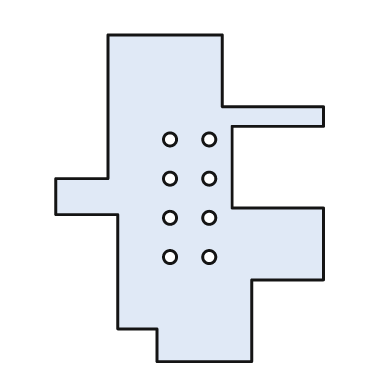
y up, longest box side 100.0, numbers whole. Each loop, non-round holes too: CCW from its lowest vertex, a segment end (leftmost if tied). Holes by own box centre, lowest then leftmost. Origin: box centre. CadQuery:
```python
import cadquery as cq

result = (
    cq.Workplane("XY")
    .moveTo(-10.0, -50.0)
    .lineTo(19.0, -50.0)
    .lineTo(19.0, -25.0)
    .lineTo(41.0, -25.0)
    .lineTo(41.0, -3.0)
    .lineTo(13.0, -3.0)
    .lineTo(13.0, 22.0)
    .lineTo(41.0, 22.0)
    .lineTo(41.0, 28.0)
    .lineTo(10.0, 28.0)
    .lineTo(10.0, 50.0)
    .lineTo(-25.0, 50.0)
    .lineTo(-25.0, 6.0)
    .lineTo(-41.0, 6.0)
    .lineTo(-41.0, -5.0)
    .lineTo(-22.0, -5.0)
    .lineTo(-22.0, -40.0)
    .lineTo(-10.0, -40.0)
    .close()
    .moveTo(-6.0, -18.0)
    .circle(2.0)
    .moveTo(6.0, -18.0)
    .circle(2.0)
    .moveTo(-6.0, -6.0)
    .circle(2.0)
    .moveTo(6.0, -6.0)
    .circle(2.0)
    .moveTo(-6.0, 6.0)
    .circle(2.0)
    .moveTo(6.0, 6.0)
    .circle(2.0)
    .moveTo(-6.0, 18.0)
    .circle(2.0)
    .moveTo(6.0, 18.0)
    .circle(2.0)
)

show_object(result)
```